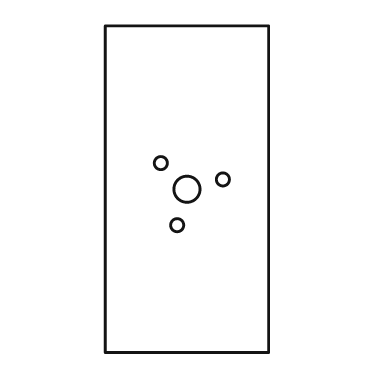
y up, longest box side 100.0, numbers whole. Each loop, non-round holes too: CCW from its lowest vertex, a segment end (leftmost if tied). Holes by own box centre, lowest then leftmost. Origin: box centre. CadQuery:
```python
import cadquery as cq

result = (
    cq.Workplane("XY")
    .moveTo(-25.0, -50.0)
    .lineTo(25.0, -50.0)
    .lineTo(25.0, 50.0)
    .lineTo(-25.0, 50.0)
    .close()
    .moveTo(-3.0, -11.0)
    .circle(2.0)
    .moveTo(0.0, 0.0)
    .circle(4.0)
    .moveTo(11.0, 3.0)
    .circle(2.0)
    .moveTo(-8.0, 8.0)
    .circle(2.0)
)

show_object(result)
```